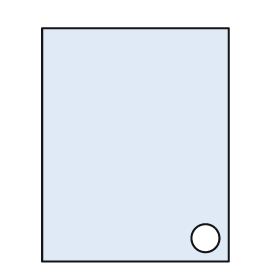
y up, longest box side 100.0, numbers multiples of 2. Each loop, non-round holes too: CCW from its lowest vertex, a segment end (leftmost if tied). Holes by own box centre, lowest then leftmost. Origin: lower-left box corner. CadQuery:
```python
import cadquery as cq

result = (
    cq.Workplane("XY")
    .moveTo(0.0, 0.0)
    .lineTo(80.0, 0.0)
    .lineTo(80.0, 100.0)
    .lineTo(0.0, 100.0)
    .close()
    .moveTo(70.0, 10.0)
    .circle(6.0)
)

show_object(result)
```